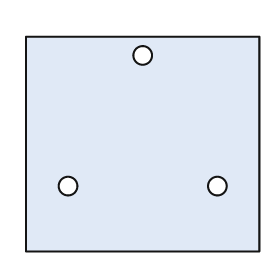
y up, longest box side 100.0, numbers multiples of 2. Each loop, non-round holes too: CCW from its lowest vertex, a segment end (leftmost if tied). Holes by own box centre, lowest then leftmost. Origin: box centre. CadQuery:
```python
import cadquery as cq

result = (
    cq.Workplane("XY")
    .moveTo(-50.0, -46.0)
    .lineTo(50.0, -46.0)
    .lineTo(50.0, 46.0)
    .lineTo(-50.0, 46.0)
    .close()
    .moveTo(-32.0, -18.0)
    .circle(4.0)
    .moveTo(32.0, -18.0)
    .circle(4.0)
    .moveTo(0.0, 38.0)
    .circle(4.0)
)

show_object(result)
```